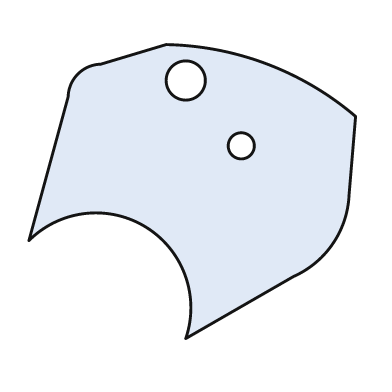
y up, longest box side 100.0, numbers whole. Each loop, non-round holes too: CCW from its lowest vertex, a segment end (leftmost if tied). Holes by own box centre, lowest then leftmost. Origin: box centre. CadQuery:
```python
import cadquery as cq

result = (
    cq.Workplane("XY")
    .moveTo(-2.0, -45.0)
    .lineTo(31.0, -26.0)
    .threePointArc((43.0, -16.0), (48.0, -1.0))
    .lineTo(50.0, 23.0)
    .threePointArc((23.0, 39.0), (-8.0, 45.0))
    .lineTo(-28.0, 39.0)
    .threePointArc((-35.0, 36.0), (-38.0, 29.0))
    .lineTo(-50.0, -15.0)
    .threePointArc((-14.0, -11.0), (-2.0, -45.0))
    .close()
    .moveTo(15.0, 14.0)
    .circle(4.0)
    .moveTo(-2.0, 34.0)
    .circle(6.0)
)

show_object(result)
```